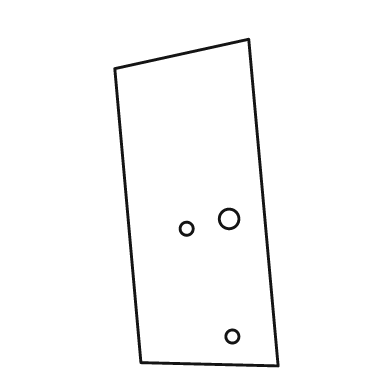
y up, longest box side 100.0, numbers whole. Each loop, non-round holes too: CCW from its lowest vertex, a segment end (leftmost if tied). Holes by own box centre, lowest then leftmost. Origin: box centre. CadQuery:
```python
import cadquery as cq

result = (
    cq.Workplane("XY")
    .moveTo(25.0, -50.0)
    .lineTo(16.0, 50.0)
    .lineTo(-25.0, 41.0)
    .lineTo(-17.0, -49.0)
    .close()
    .moveTo(11.0, -41.0)
    .circle(2.0)
    .moveTo(-3.0, -8.0)
    .circle(2.0)
    .moveTo(10.0, -5.0)
    .circle(3.0)
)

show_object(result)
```